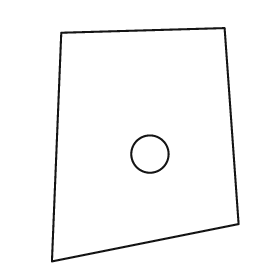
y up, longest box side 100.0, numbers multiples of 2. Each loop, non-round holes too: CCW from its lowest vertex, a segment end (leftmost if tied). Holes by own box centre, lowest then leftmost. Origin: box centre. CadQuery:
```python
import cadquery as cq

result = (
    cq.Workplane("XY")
    .moveTo(-40.0, -50.0)
    .lineTo(40.0, -34.0)
    .lineTo(34.0, 50.0)
    .lineTo(-36.0, 48.0)
    .close()
    .moveTo(2.0, -4.0)
    .circle(8.0)
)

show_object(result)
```